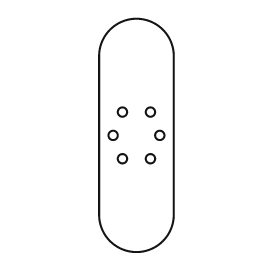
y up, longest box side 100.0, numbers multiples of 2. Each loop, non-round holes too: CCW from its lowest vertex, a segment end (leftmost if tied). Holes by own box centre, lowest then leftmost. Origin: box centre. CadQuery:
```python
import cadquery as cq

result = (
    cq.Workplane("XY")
    .moveTo(-16.0, -34.0)
    .threePointArc((0.0, -50.0), (16.0, -34.0))
    .lineTo(16.0, 34.0)
    .threePointArc((0.0, 50.0), (-16.0, 34.0))
    .close()
    .moveTo(-6.0, -10.0)
    .circle(2.0)
    .moveTo(6.0, -10.0)
    .circle(2.0)
    .moveTo(-10.0, 0.0)
    .circle(2.0)
    .moveTo(10.0, 0.0)
    .circle(2.0)
    .moveTo(-6.0, 10.0)
    .circle(2.0)
    .moveTo(6.0, 10.0)
    .circle(2.0)
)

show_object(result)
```